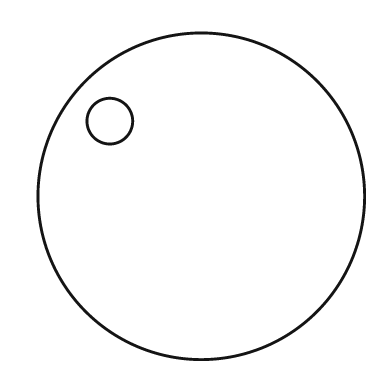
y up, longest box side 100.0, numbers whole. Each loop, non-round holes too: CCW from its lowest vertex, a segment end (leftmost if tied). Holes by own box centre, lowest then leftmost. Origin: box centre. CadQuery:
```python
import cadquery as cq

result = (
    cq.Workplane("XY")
    .moveTo(0.0, 0.0)
    .circle(50.0)
    .moveTo(-28.0, 23.0)
    .circle(7.0)
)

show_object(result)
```